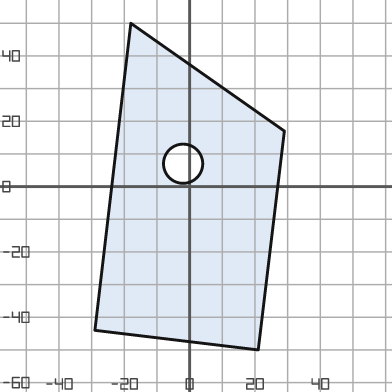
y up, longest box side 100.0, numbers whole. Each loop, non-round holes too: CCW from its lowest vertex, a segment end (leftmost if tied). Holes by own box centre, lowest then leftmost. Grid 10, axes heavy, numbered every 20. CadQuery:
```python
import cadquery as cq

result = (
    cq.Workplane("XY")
    .moveTo(21.0, -50.0)
    .lineTo(29.0, 17.0)
    .lineTo(-18.0, 50.0)
    .lineTo(-29.0, -44.0)
    .close()
    .moveTo(-2.0, 7.0)
    .circle(6.0)
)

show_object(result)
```